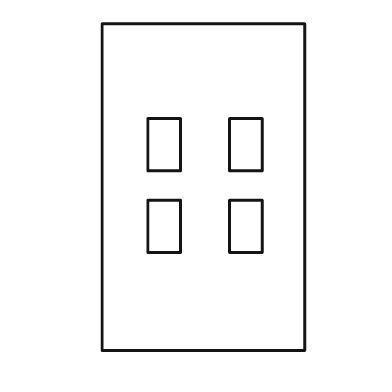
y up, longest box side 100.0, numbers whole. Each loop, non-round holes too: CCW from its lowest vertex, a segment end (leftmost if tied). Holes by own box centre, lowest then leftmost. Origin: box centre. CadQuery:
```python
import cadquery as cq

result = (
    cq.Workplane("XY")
    .moveTo(-31.0, -50.0)
    .lineTo(31.0, -50.0)
    .lineTo(31.0, 50.0)
    .lineTo(-31.0, 50.0)
    .close()
    .moveTo(-17.0, -20.0)
    .lineTo(-7.0, -20.0)
    .lineTo(-7.0, -4.0)
    .lineTo(-17.0, -4.0)
    .close()
    .moveTo(8.0, -20.0)
    .lineTo(18.0, -20.0)
    .lineTo(18.0, -4.0)
    .lineTo(8.0, -4.0)
    .close()
    .moveTo(-17.0, 5.0)
    .lineTo(-7.0, 5.0)
    .lineTo(-7.0, 21.0)
    .lineTo(-17.0, 21.0)
    .close()
    .moveTo(8.0, 5.0)
    .lineTo(18.0, 5.0)
    .lineTo(18.0, 21.0)
    .lineTo(8.0, 21.0)
    .close()
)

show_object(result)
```